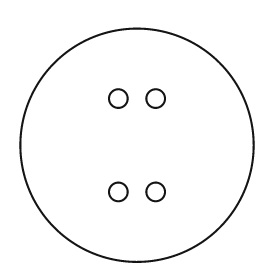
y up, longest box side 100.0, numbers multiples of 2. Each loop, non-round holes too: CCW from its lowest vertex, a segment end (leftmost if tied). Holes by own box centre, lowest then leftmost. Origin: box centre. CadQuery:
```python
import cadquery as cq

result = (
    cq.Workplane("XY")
    .moveTo(0.0, 0.0)
    .circle(50.0)
    .moveTo(-8.0, -20.0)
    .circle(4.0)
    .moveTo(8.0, -20.0)
    .circle(4.0)
    .moveTo(-8.0, 20.0)
    .circle(4.0)
    .moveTo(8.0, 20.0)
    .circle(4.0)
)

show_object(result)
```